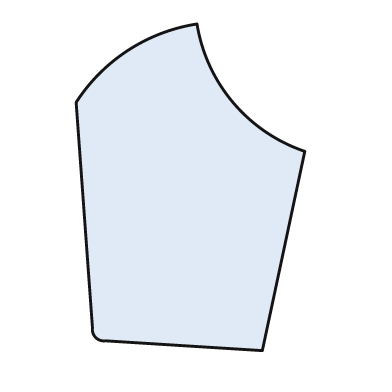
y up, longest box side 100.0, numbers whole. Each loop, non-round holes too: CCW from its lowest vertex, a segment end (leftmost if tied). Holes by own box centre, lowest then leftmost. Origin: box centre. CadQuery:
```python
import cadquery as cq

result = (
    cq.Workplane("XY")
    .moveTo(22.0, -50.0)
    .lineTo(35.0, 11.0)
    .threePointArc((13.0, 26.0), (2.0, 50.0))
    .threePointArc((-19.0, 42.0), (-35.0, 26.0))
    .lineTo(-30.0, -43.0)
    .threePointArc((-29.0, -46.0), (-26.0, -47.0))
    .close()
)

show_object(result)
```